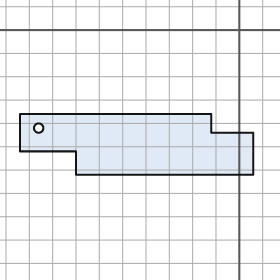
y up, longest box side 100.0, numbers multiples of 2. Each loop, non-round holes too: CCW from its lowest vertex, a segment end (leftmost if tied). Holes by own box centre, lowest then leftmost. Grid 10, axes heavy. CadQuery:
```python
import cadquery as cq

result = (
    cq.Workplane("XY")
    .moveTo(-70.0, -62.0)
    .lineTo(6.0, -62.0)
    .lineTo(6.0, -44.0)
    .lineTo(-12.0, -44.0)
    .lineTo(-12.0, -36.0)
    .lineTo(-94.0, -36.0)
    .lineTo(-94.0, -52.0)
    .lineTo(-70.0, -52.0)
    .close()
    .moveTo(-86.0, -42.0)
    .circle(2.0)
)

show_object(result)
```